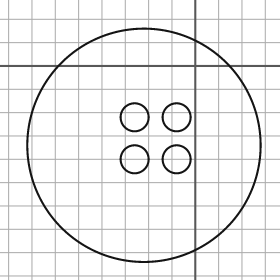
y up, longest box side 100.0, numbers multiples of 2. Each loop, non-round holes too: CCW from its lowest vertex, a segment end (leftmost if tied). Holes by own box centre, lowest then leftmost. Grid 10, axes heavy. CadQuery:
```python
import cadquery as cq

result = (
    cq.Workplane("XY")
    .moveTo(-22.0, -34.0)
    .circle(50.0)
    .moveTo(-26.0, -40.0)
    .circle(6.0)
    .moveTo(-8.0, -40.0)
    .circle(6.0)
    .moveTo(-26.0, -22.0)
    .circle(6.0)
    .moveTo(-8.0, -22.0)
    .circle(6.0)
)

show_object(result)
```